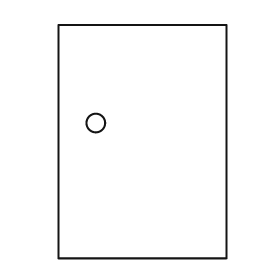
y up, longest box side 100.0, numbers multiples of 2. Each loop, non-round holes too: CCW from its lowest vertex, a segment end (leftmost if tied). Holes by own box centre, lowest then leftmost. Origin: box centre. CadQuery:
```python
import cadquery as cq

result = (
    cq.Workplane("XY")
    .moveTo(-36.0, -50.0)
    .lineTo(36.0, -50.0)
    .lineTo(36.0, 50.0)
    .lineTo(-36.0, 50.0)
    .close()
    .moveTo(-20.0, 8.0)
    .circle(4.0)
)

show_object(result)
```